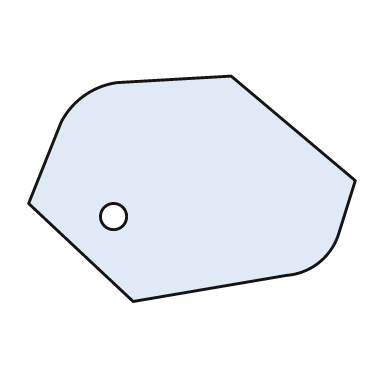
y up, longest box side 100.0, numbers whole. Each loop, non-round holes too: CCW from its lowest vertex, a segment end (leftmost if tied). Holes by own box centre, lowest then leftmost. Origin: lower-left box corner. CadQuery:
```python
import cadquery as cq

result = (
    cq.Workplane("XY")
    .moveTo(32.0, 0.0)
    .lineTo(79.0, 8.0)
    .threePointArc((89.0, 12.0), (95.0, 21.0))
    .lineTo(100.0, 37.0)
    .lineTo(62.0, 69.0)
    .lineTo(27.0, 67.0)
    .threePointArc((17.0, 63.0), (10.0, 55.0))
    .lineTo(0.0, 30.0)
    .close()
    .moveTo(26.0, 26.0)
    .circle(4.0)
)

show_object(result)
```